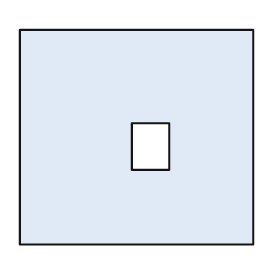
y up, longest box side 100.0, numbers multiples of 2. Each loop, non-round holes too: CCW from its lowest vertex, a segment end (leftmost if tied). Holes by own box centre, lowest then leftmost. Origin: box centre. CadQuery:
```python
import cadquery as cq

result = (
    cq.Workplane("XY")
    .moveTo(-50.0, -46.0)
    .lineTo(50.0, -46.0)
    .lineTo(50.0, 46.0)
    .lineTo(-50.0, 46.0)
    .close()
    .moveTo(-2.0, -14.0)
    .lineTo(14.0, -14.0)
    .lineTo(14.0, 6.0)
    .lineTo(-2.0, 6.0)
    .close()
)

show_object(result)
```